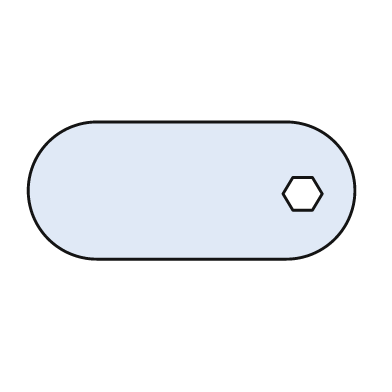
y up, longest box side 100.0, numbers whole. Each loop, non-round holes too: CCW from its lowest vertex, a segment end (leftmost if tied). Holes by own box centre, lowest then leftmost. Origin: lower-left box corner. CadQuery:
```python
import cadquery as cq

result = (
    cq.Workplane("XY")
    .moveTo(21.0, 0.0)
    .lineTo(79.0, 0.0)
    .threePointArc((100.0, 21.0), (79.0, 42.0))
    .lineTo(21.0, 42.0)
    .threePointArc((0.0, 21.0), (21.0, 0.0))
    .close()
    .moveTo(81.0, 15.0)
    .lineTo(87.0, 15.0)
    .lineTo(90.0, 20.0)
    .lineTo(87.0, 25.0)
    .lineTo(81.0, 25.0)
    .lineTo(78.0, 20.0)
    .close()
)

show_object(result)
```